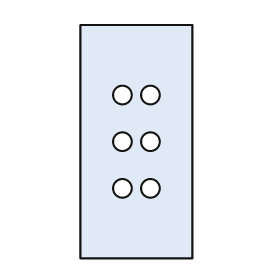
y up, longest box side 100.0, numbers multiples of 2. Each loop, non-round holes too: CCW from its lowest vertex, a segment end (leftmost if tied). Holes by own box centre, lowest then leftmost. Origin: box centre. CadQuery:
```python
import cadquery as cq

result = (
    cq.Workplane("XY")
    .moveTo(-24.0, -50.0)
    .lineTo(24.0, -50.0)
    .lineTo(24.0, 50.0)
    .lineTo(-24.0, 50.0)
    .close()
    .moveTo(-6.0, -20.0)
    .circle(4.0)
    .moveTo(6.0, -20.0)
    .circle(4.0)
    .moveTo(-6.0, 0.0)
    .circle(4.0)
    .moveTo(6.0, 0.0)
    .circle(4.0)
    .moveTo(-6.0, 20.0)
    .circle(4.0)
    .moveTo(6.0, 20.0)
    .circle(4.0)
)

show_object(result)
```